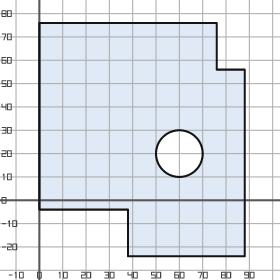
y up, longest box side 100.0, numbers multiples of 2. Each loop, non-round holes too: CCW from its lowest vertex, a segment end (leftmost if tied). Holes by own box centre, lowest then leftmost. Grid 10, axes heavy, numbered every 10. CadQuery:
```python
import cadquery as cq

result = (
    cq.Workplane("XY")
    .moveTo(38.0, -24.0)
    .lineTo(88.0, -24.0)
    .lineTo(88.0, 56.0)
    .lineTo(76.0, 56.0)
    .lineTo(76.0, 76.0)
    .lineTo(0.0, 76.0)
    .lineTo(0.0, -4.0)
    .lineTo(38.0, -4.0)
    .close()
    .moveTo(60.0, 20.0)
    .circle(10.0)
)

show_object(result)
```